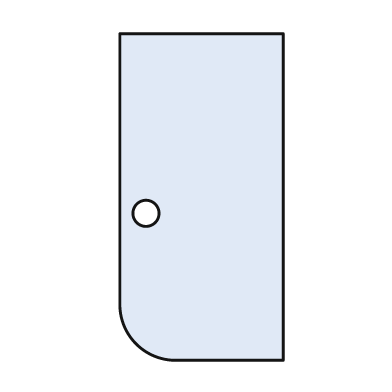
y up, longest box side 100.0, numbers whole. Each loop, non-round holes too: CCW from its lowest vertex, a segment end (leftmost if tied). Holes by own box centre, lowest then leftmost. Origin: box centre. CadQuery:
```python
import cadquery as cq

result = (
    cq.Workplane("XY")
    .moveTo(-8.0, -50.0)
    .lineTo(25.0, -50.0)
    .lineTo(25.0, 50.0)
    .lineTo(-25.0, 50.0)
    .lineTo(-25.0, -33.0)
    .threePointArc((-20.0, -45.0), (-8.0, -50.0))
    .close()
    .moveTo(-17.0, -5.0)
    .circle(4.0)
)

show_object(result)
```